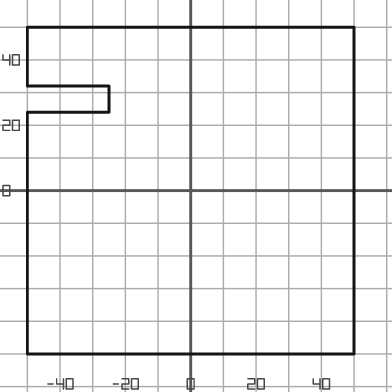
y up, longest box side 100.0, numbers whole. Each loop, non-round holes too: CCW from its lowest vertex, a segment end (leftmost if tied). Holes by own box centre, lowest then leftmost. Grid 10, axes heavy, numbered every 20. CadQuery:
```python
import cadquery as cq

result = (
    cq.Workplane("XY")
    .moveTo(-50.0, -50.0)
    .lineTo(50.0, -50.0)
    .lineTo(50.0, 50.0)
    .lineTo(-50.0, 50.0)
    .lineTo(-50.0, 32.0)
    .lineTo(-25.0, 32.0)
    .lineTo(-25.0, 24.0)
    .lineTo(-50.0, 24.0)
    .close()
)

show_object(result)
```